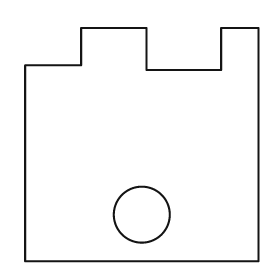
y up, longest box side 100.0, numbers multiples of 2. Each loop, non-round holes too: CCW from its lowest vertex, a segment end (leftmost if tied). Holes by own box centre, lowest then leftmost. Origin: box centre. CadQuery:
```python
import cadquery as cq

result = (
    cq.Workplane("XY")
    .moveTo(-50.0, -50.0)
    .lineTo(50.0, -50.0)
    .lineTo(50.0, 50.0)
    .lineTo(34.0, 50.0)
    .lineTo(34.0, 32.0)
    .lineTo(2.0, 32.0)
    .lineTo(2.0, 50.0)
    .lineTo(-26.0, 50.0)
    .lineTo(-26.0, 34.0)
    .lineTo(-50.0, 34.0)
    .close()
    .moveTo(0.0, -30.0)
    .circle(12.0)
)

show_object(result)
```